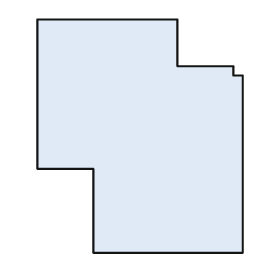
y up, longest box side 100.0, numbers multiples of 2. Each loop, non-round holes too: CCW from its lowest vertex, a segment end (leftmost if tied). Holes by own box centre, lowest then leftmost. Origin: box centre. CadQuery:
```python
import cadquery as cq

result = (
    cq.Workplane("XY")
    .moveTo(-20.0, -50.0)
    .lineTo(44.0, -50.0)
    .lineTo(44.0, 26.0)
    .lineTo(40.0, 26.0)
    .lineTo(40.0, 30.0)
    .lineTo(16.0, 30.0)
    .lineTo(16.0, 50.0)
    .lineTo(-44.0, 50.0)
    .lineTo(-44.0, -14.0)
    .lineTo(-20.0, -14.0)
    .close()
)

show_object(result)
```